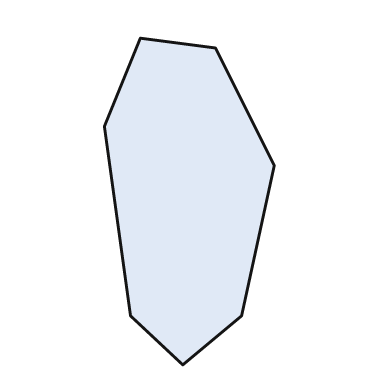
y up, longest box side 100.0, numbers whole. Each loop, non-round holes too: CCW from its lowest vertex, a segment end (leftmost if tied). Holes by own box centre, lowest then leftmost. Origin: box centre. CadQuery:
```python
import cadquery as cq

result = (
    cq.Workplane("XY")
    .moveTo(-2.0, -50.0)
    .lineTo(16.0, -35.0)
    .lineTo(26.0, 11.0)
    .lineTo(8.0, 47.0)
    .lineTo(-15.0, 50.0)
    .lineTo(-26.0, 23.0)
    .lineTo(-18.0, -35.0)
    .close()
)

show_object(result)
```